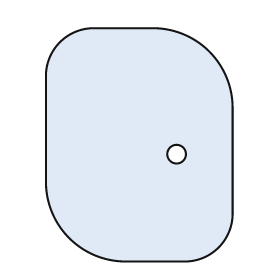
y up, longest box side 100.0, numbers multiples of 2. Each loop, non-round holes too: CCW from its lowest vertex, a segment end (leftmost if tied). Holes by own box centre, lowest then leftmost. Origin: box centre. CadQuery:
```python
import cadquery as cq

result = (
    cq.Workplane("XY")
    .moveTo(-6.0, -50.0)
    .lineTo(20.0, -50.0)
    .threePointArc((34.0, -44.0), (40.0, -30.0))
    .lineTo(40.0, 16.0)
    .threePointArc((30.0, 40.0), (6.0, 50.0))
    .lineTo(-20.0, 50.0)
    .threePointArc((-34.0, 44.0), (-40.0, 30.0))
    .lineTo(-40.0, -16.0)
    .threePointArc((-30.0, -40.0), (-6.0, -50.0))
    .close()
    .moveTo(16.0, -4.0)
    .circle(4.0)
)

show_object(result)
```